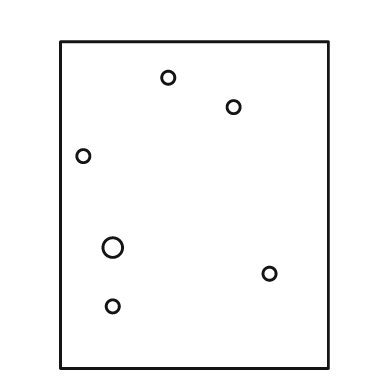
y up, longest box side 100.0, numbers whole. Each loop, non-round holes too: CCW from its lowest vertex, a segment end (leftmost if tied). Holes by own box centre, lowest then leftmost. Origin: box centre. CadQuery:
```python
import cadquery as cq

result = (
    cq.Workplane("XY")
    .moveTo(-41.0, -50.0)
    .lineTo(41.0, -50.0)
    .lineTo(41.0, 50.0)
    .lineTo(-41.0, 50.0)
    .close()
    .moveTo(-25.0, -31.0)
    .circle(2.0)
    .moveTo(23.0, -21.0)
    .circle(2.0)
    .moveTo(-25.0, -13.0)
    .circle(3.0)
    .moveTo(-34.0, 15.0)
    .circle(2.0)
    .moveTo(12.0, 30.0)
    .circle(2.0)
    .moveTo(-8.0, 39.0)
    .circle(2.0)
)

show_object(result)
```